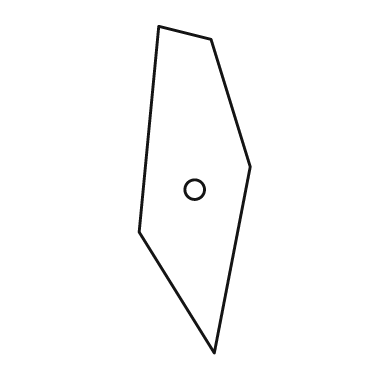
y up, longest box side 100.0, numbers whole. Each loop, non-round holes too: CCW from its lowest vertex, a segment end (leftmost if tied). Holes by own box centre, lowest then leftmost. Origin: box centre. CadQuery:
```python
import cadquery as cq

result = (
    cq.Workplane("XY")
    .moveTo(6.0, -50.0)
    .lineTo(17.0, 7.0)
    .lineTo(5.0, 46.0)
    .lineTo(-11.0, 50.0)
    .lineTo(-17.0, -13.0)
    .close()
    .moveTo(0.0, 0.0)
    .circle(3.0)
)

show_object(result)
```